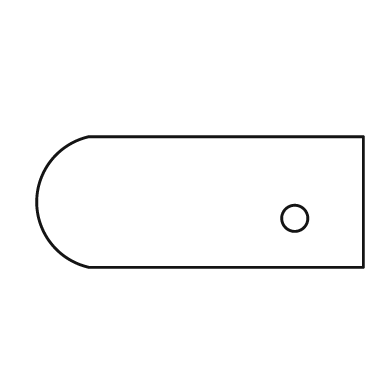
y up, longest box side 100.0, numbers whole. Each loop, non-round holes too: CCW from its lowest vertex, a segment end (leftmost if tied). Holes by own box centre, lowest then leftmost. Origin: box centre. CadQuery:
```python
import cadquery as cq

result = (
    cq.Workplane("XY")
    .moveTo(-34.0, -20.0)
    .lineTo(50.0, -20.0)
    .lineTo(50.0, 20.0)
    .lineTo(-34.0, 20.0)
    .threePointArc((-50.0, 0.0), (-34.0, -20.0))
    .close()
    .moveTo(29.0, -5.0)
    .circle(4.0)
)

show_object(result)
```